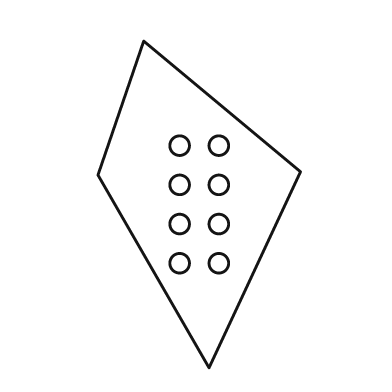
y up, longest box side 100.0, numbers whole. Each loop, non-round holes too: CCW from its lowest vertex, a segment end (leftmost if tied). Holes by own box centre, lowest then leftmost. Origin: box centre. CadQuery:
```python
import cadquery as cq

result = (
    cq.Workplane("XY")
    .moveTo(3.0, -50.0)
    .lineTo(31.0, 10.0)
    .lineTo(-17.0, 50.0)
    .lineTo(-31.0, 9.0)
    .close()
    .moveTo(-6.0, -18.0)
    .circle(3.0)
    .moveTo(6.0, -18.0)
    .circle(3.0)
    .moveTo(-6.0, -6.0)
    .circle(3.0)
    .moveTo(6.0, -6.0)
    .circle(3.0)
    .moveTo(-6.0, 6.0)
    .circle(3.0)
    .moveTo(6.0, 6.0)
    .circle(3.0)
    .moveTo(-6.0, 18.0)
    .circle(3.0)
    .moveTo(6.0, 18.0)
    .circle(3.0)
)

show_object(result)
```